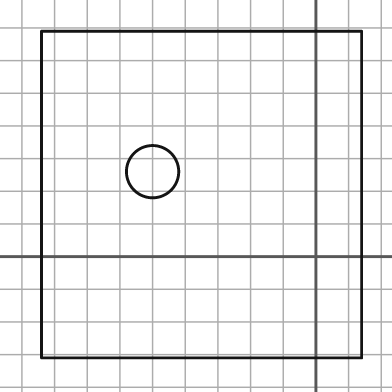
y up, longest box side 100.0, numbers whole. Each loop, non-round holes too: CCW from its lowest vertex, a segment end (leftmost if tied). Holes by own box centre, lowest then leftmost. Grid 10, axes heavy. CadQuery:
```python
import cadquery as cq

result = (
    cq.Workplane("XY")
    .moveTo(-84.0, -31.0)
    .lineTo(14.0, -31.0)
    .lineTo(14.0, 69.0)
    .lineTo(-84.0, 69.0)
    .close()
    .moveTo(-50.0, 26.0)
    .circle(8.0)
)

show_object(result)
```